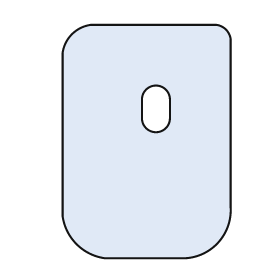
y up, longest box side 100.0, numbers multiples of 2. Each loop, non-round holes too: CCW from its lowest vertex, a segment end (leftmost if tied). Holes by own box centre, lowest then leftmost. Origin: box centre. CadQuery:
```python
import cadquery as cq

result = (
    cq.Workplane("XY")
    .moveTo(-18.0, -50.0)
    .lineTo(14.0, -50.0)
    .threePointArc((30.0, -44.0), (36.0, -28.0))
    .lineTo(36.0, 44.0)
    .threePointArc((34.0, 48.0), (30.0, 50.0))
    .lineTo(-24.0, 50.0)
    .threePointArc((-32.0, 46.0), (-36.0, 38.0))
    .lineTo(-36.0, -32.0)
    .threePointArc((-30.0, -44.0), (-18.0, -50.0))
    .close()
    .moveTo(-2.0, 10.0)
    .threePointArc((4.0, 4.0), (10.0, 10.0))
    .lineTo(10.0, 18.0)
    .threePointArc((4.0, 24.0), (-2.0, 18.0))
    .close()
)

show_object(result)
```